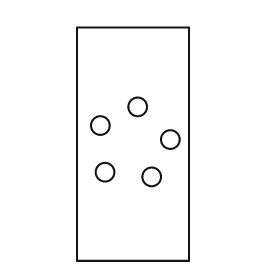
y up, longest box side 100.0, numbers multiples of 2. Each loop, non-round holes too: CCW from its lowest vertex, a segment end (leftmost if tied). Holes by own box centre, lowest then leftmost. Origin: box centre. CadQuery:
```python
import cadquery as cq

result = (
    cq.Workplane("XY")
    .moveTo(-24.0, -50.0)
    .lineTo(24.0, -50.0)
    .lineTo(24.0, 50.0)
    .lineTo(-24.0, 50.0)
    .close()
    .moveTo(8.0, -14.0)
    .circle(4.0)
    .moveTo(-12.0, -12.0)
    .circle(4.0)
    .moveTo(16.0, 2.0)
    .circle(4.0)
    .moveTo(-14.0, 8.0)
    .circle(4.0)
    .moveTo(2.0, 16.0)
    .circle(4.0)
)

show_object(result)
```